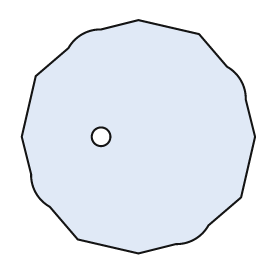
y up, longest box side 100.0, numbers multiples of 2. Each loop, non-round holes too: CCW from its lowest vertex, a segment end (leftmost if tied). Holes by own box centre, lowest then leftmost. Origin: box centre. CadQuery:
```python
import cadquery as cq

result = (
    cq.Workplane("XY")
    .moveTo(0.0, -50.0)
    .lineTo(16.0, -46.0)
    .threePointArc((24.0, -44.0), (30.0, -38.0))
    .lineTo(44.0, -26.0)
    .lineTo(50.0, 0.0)
    .lineTo(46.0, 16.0)
    .threePointArc((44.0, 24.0), (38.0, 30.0))
    .lineTo(26.0, 44.0)
    .lineTo(0.0, 50.0)
    .lineTo(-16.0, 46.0)
    .threePointArc((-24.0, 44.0), (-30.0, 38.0))
    .lineTo(-44.0, 26.0)
    .lineTo(-50.0, 0.0)
    .lineTo(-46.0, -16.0)
    .threePointArc((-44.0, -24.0), (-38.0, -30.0))
    .lineTo(-26.0, -44.0)
    .close()
    .moveTo(-16.0, 0.0)
    .circle(4.0)
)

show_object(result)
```